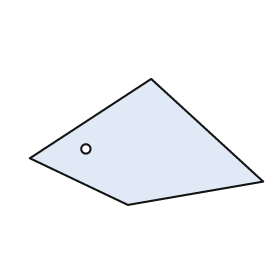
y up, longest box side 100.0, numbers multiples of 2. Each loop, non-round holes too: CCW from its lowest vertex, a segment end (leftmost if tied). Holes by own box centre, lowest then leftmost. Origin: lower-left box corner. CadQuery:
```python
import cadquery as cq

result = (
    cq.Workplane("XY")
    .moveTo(42.0, 0.0)
    .lineTo(100.0, 10.0)
    .lineTo(52.0, 54.0)
    .lineTo(0.0, 20.0)
    .close()
    .moveTo(24.0, 24.0)
    .circle(2.0)
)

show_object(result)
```